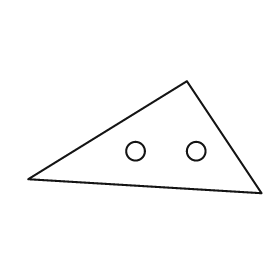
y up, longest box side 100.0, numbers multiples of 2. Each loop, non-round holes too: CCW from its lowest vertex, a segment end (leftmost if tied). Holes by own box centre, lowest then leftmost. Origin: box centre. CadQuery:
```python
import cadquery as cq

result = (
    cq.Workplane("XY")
    .moveTo(50.0, -24.0)
    .lineTo(18.0, 24.0)
    .lineTo(-50.0, -18.0)
    .close()
    .moveTo(-4.0, -6.0)
    .circle(4.0)
    .moveTo(22.0, -6.0)
    .circle(4.0)
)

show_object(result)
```